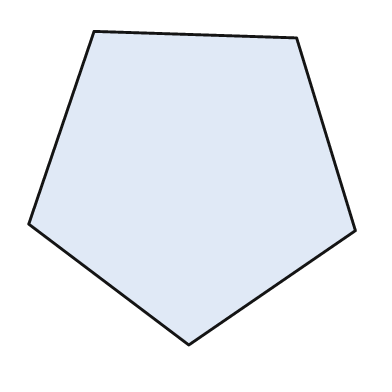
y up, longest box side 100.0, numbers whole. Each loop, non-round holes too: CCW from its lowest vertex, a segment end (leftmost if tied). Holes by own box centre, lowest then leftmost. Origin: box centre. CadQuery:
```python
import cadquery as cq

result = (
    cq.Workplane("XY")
    .moveTo(-1.0, -48.0)
    .lineTo(50.0, -13.0)
    .lineTo(32.0, 46.0)
    .lineTo(-30.0, 48.0)
    .lineTo(-50.0, -11.0)
    .close()
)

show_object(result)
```